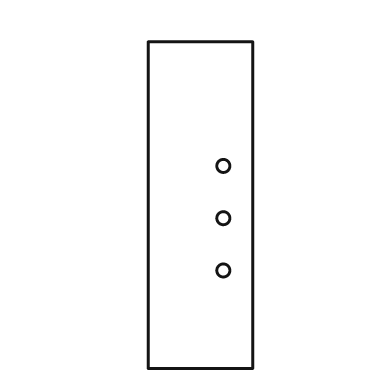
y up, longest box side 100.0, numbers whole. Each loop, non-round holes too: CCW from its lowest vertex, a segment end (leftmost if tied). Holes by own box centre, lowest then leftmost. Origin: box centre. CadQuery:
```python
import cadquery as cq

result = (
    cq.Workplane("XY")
    .moveTo(-16.0, -50.0)
    .lineTo(16.0, -50.0)
    .lineTo(16.0, 50.0)
    .lineTo(-16.0, 50.0)
    .close()
    .moveTo(7.0, -20.0)
    .circle(2.0)
    .moveTo(7.0, -4.0)
    .circle(2.0)
    .moveTo(7.0, 12.0)
    .circle(2.0)
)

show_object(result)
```